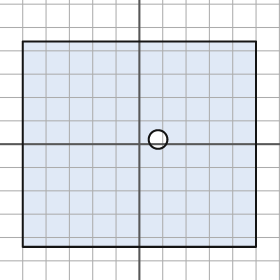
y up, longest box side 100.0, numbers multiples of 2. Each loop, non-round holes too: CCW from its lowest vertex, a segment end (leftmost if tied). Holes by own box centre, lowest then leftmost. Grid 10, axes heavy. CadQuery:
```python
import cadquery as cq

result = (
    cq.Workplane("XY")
    .moveTo(-50.0, -44.0)
    .lineTo(50.0, -44.0)
    .lineTo(50.0, 44.0)
    .lineTo(-50.0, 44.0)
    .close()
    .moveTo(8.0, 2.0)
    .circle(4.0)
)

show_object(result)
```